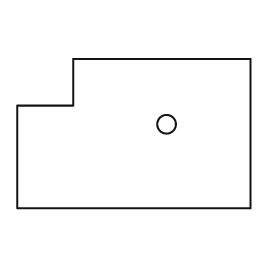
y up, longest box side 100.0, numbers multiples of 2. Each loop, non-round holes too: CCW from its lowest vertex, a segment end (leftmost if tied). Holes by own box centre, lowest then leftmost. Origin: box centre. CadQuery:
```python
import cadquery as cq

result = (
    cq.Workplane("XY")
    .moveTo(-50.0, -32.0)
    .lineTo(50.0, -32.0)
    .lineTo(50.0, 32.0)
    .lineTo(-26.0, 32.0)
    .lineTo(-26.0, 12.0)
    .lineTo(-50.0, 12.0)
    .close()
    .moveTo(14.0, 4.0)
    .circle(4.0)
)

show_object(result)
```